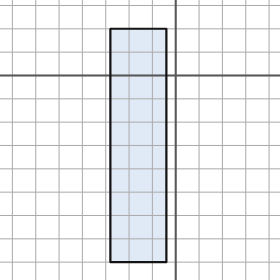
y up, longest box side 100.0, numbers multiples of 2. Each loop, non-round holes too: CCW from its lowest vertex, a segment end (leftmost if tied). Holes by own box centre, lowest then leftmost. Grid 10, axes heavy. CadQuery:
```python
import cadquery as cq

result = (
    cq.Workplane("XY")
    .moveTo(-28.0, -80.0)
    .lineTo(-4.0, -80.0)
    .lineTo(-4.0, 20.0)
    .lineTo(-28.0, 20.0)
    .close()
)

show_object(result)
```